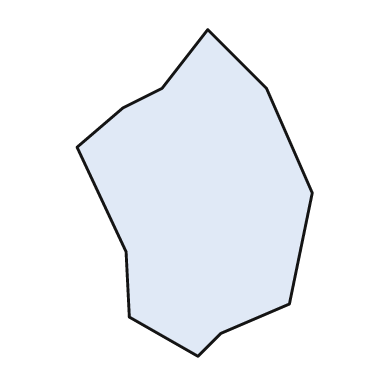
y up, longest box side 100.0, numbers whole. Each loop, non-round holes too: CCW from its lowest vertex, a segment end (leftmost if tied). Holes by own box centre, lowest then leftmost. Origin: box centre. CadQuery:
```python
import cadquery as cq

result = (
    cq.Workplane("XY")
    .moveTo(1.0, -50.0)
    .lineTo(8.0, -43.0)
    .lineTo(29.0, -34.0)
    .lineTo(36.0, 0.0)
    .lineTo(22.0, 32.0)
    .lineTo(4.0, 50.0)
    .lineTo(-10.0, 32.0)
    .lineTo(-22.0, 26.0)
    .lineTo(-36.0, 14.0)
    .lineTo(-21.0, -18.0)
    .lineTo(-20.0, -38.0)
    .close()
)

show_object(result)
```